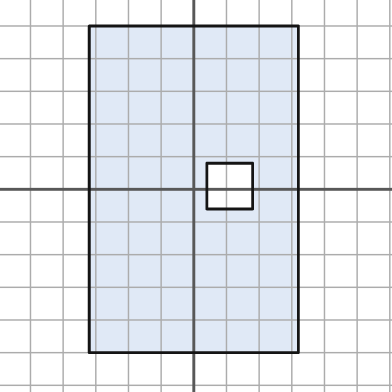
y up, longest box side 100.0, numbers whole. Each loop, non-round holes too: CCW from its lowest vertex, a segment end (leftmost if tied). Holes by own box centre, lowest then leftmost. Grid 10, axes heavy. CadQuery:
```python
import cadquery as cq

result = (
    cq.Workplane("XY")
    .moveTo(-32.0, -50.0)
    .lineTo(32.0, -50.0)
    .lineTo(32.0, 50.0)
    .lineTo(-32.0, 50.0)
    .close()
    .moveTo(4.0, -6.0)
    .lineTo(18.0, -6.0)
    .lineTo(18.0, 8.0)
    .lineTo(4.0, 8.0)
    .close()
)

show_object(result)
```